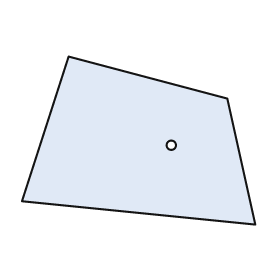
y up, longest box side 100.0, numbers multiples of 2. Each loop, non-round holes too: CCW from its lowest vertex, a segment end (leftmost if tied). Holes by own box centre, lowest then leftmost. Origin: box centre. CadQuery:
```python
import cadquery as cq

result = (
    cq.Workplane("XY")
    .moveTo(50.0, -36.0)
    .lineTo(38.0, 18.0)
    .lineTo(-30.0, 36.0)
    .lineTo(-50.0, -26.0)
    .close()
    .moveTo(14.0, -2.0)
    .circle(2.0)
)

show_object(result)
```